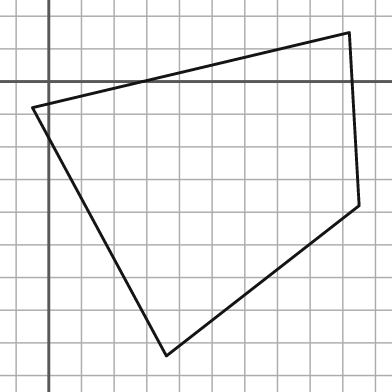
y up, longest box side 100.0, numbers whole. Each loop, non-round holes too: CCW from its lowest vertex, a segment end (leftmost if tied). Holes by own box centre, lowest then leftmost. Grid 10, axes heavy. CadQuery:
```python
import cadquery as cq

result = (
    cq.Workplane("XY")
    .moveTo(36.0, -84.0)
    .lineTo(95.0, -38.0)
    .lineTo(92.0, 15.0)
    .lineTo(-5.0, -8.0)
    .close()
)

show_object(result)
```